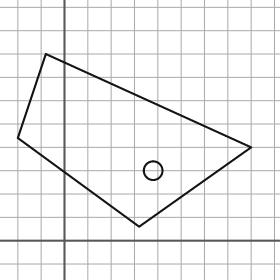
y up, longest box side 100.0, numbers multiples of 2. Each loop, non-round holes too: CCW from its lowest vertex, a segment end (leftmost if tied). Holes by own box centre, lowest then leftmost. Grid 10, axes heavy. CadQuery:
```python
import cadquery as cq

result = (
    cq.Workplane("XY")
    .moveTo(32.0, 6.0)
    .lineTo(80.0, 40.0)
    .lineTo(-8.0, 80.0)
    .lineTo(-20.0, 44.0)
    .close()
    .moveTo(38.0, 30.0)
    .circle(4.0)
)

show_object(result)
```